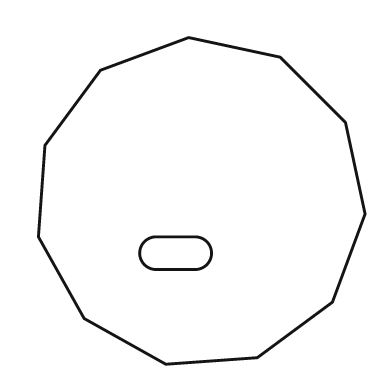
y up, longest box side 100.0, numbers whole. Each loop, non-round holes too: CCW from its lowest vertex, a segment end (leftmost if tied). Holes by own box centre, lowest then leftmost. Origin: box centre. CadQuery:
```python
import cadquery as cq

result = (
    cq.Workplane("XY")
    .moveTo(-11.0, -50.0)
    .lineTo(17.0, -48.0)
    .lineTo(40.0, -31.0)
    .lineTo(50.0, -4.0)
    .lineTo(44.0, 24.0)
    .lineTo(24.0, 44.0)
    .lineTo(-4.0, 50.0)
    .lineTo(-31.0, 40.0)
    .lineTo(-48.0, 17.0)
    .lineTo(-50.0, -11.0)
    .lineTo(-36.0, -36.0)
    .close()
    .moveTo(-14.0, -21.0)
    .lineTo(-2.0, -21.0)
    .threePointArc((3.0, -16.0), (-2.0, -11.0))
    .lineTo(-14.0, -11.0)
    .threePointArc((-19.0, -16.0), (-14.0, -21.0))
    .close()
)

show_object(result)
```